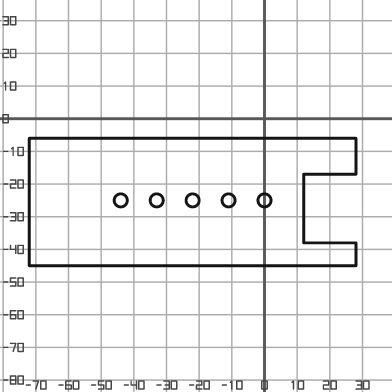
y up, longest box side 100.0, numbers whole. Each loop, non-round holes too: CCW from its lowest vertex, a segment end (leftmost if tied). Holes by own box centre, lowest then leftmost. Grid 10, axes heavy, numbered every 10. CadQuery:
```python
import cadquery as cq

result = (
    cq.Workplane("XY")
    .moveTo(-72.0, -45.0)
    .lineTo(28.0, -45.0)
    .lineTo(28.0, -38.0)
    .lineTo(12.0, -38.0)
    .lineTo(12.0, -17.0)
    .lineTo(28.0, -17.0)
    .lineTo(28.0, -6.0)
    .lineTo(-72.0, -6.0)
    .close()
    .moveTo(-44.0, -25.0)
    .circle(2.0)
    .moveTo(-33.0, -25.0)
    .circle(2.0)
    .moveTo(-22.0, -25.0)
    .circle(2.0)
    .moveTo(-11.0, -25.0)
    .circle(2.0)
    .moveTo(0.0, -25.0)
    .circle(2.0)
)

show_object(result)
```